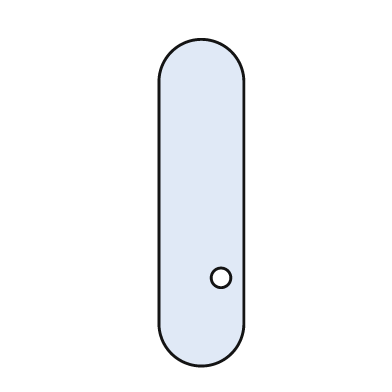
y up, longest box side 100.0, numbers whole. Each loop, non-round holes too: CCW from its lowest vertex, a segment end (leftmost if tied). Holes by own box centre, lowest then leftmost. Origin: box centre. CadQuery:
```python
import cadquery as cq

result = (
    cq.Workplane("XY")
    .moveTo(-13.0, -37.0)
    .threePointArc((0.0, -50.0), (13.0, -37.0))
    .lineTo(13.0, 37.0)
    .threePointArc((0.0, 50.0), (-13.0, 37.0))
    .close()
    .moveTo(6.0, -23.0)
    .circle(3.0)
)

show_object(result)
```